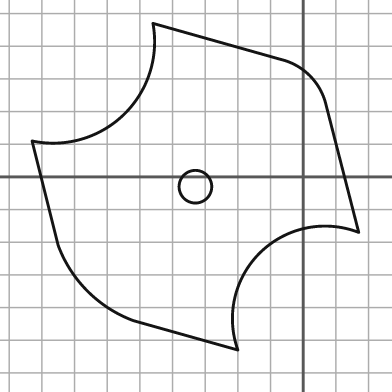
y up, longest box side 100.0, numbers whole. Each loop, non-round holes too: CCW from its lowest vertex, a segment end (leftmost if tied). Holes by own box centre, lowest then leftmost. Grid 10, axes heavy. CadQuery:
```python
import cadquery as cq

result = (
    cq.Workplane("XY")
    .moveTo(-20.0, -53.0)
    .threePointArc((-13.0, -23.0), (17.0, -17.0))
    .lineTo(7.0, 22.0)
    .threePointArc((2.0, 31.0), (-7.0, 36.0))
    .lineTo(-46.0, 47.0)
    .threePointArc((-55.0, 19.0), (-83.0, 11.0))
    .lineTo(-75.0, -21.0)
    .threePointArc((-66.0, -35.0), (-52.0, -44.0))
    .close()
    .moveTo(-33.0, -3.0)
    .circle(5.0)
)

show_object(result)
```